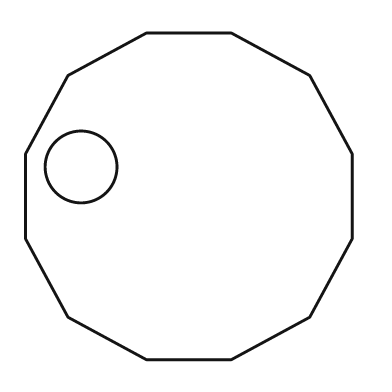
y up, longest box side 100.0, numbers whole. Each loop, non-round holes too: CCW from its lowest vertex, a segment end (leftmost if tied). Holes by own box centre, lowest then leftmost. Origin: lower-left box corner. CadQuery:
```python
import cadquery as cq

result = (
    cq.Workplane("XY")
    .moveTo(37.0, 0.0)
    .lineTo(63.0, 0.0)
    .lineTo(87.0, 13.0)
    .lineTo(100.0, 37.0)
    .lineTo(100.0, 63.0)
    .lineTo(87.0, 87.0)
    .lineTo(63.0, 100.0)
    .lineTo(37.0, 100.0)
    .lineTo(13.0, 87.0)
    .lineTo(0.0, 63.0)
    .lineTo(0.0, 37.0)
    .lineTo(13.0, 13.0)
    .close()
    .moveTo(17.0, 59.0)
    .circle(11.0)
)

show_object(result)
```